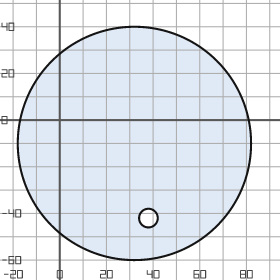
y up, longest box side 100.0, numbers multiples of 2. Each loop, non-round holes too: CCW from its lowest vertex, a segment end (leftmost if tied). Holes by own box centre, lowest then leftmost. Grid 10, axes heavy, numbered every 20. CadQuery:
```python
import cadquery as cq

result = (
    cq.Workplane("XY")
    .moveTo(32.0, -10.0)
    .circle(50.0)
    .moveTo(38.0, -42.0)
    .circle(4.0)
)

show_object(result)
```